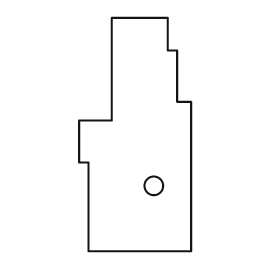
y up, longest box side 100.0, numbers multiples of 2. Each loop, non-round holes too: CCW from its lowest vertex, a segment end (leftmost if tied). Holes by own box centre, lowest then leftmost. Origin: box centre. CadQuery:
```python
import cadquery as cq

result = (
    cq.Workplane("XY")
    .moveTo(-20.0, -50.0)
    .lineTo(24.0, -50.0)
    .lineTo(24.0, 14.0)
    .lineTo(18.0, 14.0)
    .lineTo(18.0, 36.0)
    .lineTo(14.0, 36.0)
    .lineTo(14.0, 50.0)
    .lineTo(-10.0, 50.0)
    .lineTo(-10.0, 6.0)
    .lineTo(-24.0, 6.0)
    .lineTo(-24.0, -12.0)
    .lineTo(-20.0, -12.0)
    .close()
    .moveTo(8.0, -22.0)
    .circle(4.0)
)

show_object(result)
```